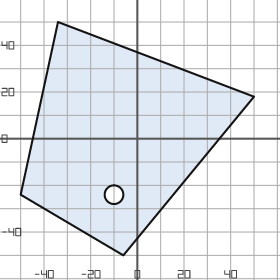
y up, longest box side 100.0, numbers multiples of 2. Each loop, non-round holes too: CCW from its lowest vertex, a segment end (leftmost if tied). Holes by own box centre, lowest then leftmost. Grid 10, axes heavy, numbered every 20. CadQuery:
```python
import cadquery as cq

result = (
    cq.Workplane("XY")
    .moveTo(-6.0, -50.0)
    .lineTo(50.0, 18.0)
    .lineTo(-34.0, 50.0)
    .lineTo(-50.0, -24.0)
    .close()
    .moveTo(-10.0, -24.0)
    .circle(4.0)
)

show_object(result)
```